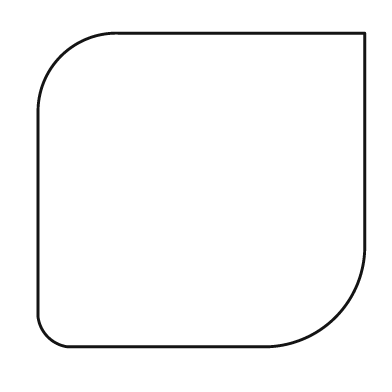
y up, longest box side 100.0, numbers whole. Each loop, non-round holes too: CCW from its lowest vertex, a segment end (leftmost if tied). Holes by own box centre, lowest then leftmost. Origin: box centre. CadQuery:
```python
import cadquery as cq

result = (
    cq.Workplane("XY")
    .moveTo(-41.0, -48.0)
    .lineTo(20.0, -48.0)
    .threePointArc((41.0, -39.0), (50.0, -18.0))
    .lineTo(50.0, 48.0)
    .lineTo(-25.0, 48.0)
    .threePointArc((-43.0, 41.0), (-50.0, 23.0))
    .lineTo(-50.0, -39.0)
    .threePointArc((-47.0, -45.0), (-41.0, -48.0))
    .close()
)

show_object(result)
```